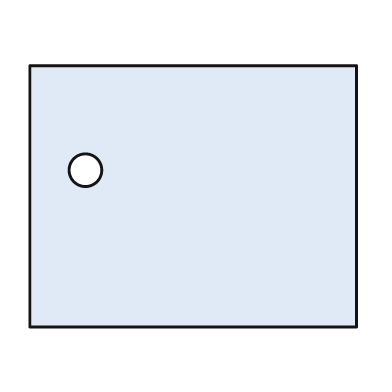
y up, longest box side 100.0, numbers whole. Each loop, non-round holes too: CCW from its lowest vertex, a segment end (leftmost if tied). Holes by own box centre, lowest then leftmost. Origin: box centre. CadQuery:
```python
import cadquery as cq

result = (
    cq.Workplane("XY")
    .moveTo(-50.0, -40.0)
    .lineTo(50.0, -40.0)
    .lineTo(50.0, 40.0)
    .lineTo(-50.0, 40.0)
    .close()
    .moveTo(-33.0, 8.0)
    .circle(5.0)
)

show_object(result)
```